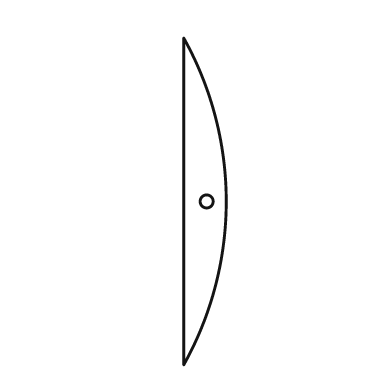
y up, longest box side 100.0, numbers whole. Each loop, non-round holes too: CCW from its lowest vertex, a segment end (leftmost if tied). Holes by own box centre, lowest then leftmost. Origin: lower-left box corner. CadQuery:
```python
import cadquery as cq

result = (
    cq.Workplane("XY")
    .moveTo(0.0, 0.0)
    .threePointArc((13.0, 50.0), (0.0, 100.0))
    .close()
    .moveTo(7.0, 50.0)
    .circle(2.0)
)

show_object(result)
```